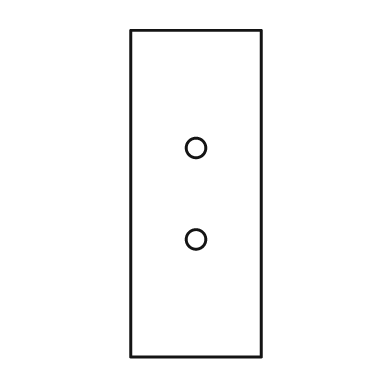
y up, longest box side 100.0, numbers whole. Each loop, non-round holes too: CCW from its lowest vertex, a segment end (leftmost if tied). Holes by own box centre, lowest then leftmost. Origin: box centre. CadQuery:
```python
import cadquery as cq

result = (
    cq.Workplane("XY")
    .moveTo(-20.0, -50.0)
    .lineTo(20.0, -50.0)
    .lineTo(20.0, 50.0)
    .lineTo(-20.0, 50.0)
    .close()
    .moveTo(0.0, -14.0)
    .circle(3.0)
    .moveTo(0.0, 14.0)
    .circle(3.0)
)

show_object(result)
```